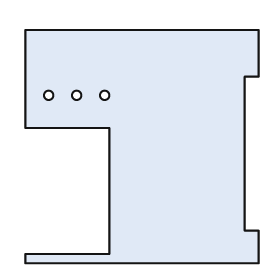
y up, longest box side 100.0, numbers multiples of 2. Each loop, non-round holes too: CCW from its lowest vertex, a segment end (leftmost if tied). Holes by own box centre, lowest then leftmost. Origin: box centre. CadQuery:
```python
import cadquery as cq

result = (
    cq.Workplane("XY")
    .moveTo(-50.0, -50.0)
    .lineTo(50.0, -50.0)
    .lineTo(50.0, -36.0)
    .lineTo(44.0, -36.0)
    .lineTo(44.0, 30.0)
    .lineTo(50.0, 30.0)
    .lineTo(50.0, 50.0)
    .lineTo(-50.0, 50.0)
    .lineTo(-50.0, 8.0)
    .lineTo(-14.0, 8.0)
    .lineTo(-14.0, -46.0)
    .lineTo(-50.0, -46.0)
    .close()
    .moveTo(-40.0, 22.0)
    .circle(2.0)
    .moveTo(-28.0, 22.0)
    .circle(2.0)
    .moveTo(-16.0, 22.0)
    .circle(2.0)
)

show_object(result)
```